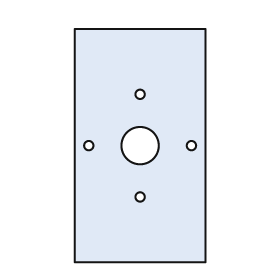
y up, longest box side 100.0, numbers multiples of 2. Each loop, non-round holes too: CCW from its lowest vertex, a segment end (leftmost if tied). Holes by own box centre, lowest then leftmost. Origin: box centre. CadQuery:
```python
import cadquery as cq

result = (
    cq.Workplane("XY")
    .moveTo(-28.0, -50.0)
    .lineTo(28.0, -50.0)
    .lineTo(28.0, 50.0)
    .lineTo(-28.0, 50.0)
    .close()
    .moveTo(0.0, -22.0)
    .circle(2.0)
    .moveTo(-22.0, 0.0)
    .circle(2.0)
    .moveTo(0.0, 0.0)
    .circle(8.0)
    .moveTo(22.0, 0.0)
    .circle(2.0)
    .moveTo(0.0, 22.0)
    .circle(2.0)
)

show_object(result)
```